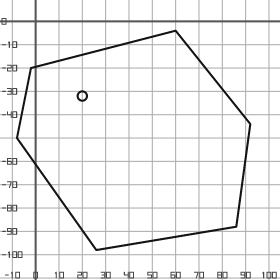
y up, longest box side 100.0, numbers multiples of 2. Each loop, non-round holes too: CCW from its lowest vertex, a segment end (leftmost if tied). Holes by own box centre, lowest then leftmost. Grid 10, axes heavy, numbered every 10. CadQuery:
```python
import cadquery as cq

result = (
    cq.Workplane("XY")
    .moveTo(26.0, -98.0)
    .lineTo(86.0, -88.0)
    .lineTo(92.0, -44.0)
    .lineTo(60.0, -4.0)
    .lineTo(-2.0, -20.0)
    .lineTo(-8.0, -50.0)
    .close()
    .moveTo(20.0, -32.0)
    .circle(2.0)
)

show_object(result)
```